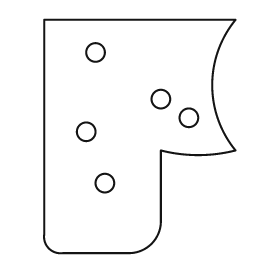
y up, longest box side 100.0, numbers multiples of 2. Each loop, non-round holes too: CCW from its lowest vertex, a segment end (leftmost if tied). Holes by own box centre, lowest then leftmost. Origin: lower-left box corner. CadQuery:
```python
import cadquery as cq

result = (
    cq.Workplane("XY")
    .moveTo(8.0, 0.0)
    .lineTo(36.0, 0.0)
    .threePointArc((46.0, 4.0), (50.0, 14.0))
    .lineTo(50.0, 44.0)
    .threePointArc((66.0, 42.0), (82.0, 44.0))
    .threePointArc((72.0, 72.0), (82.0, 100.0))
    .lineTo(0.0, 100.0)
    .lineTo(0.0, 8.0)
    .threePointArc((2.0, 2.0), (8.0, 0.0))
    .close()
    .moveTo(26.0, 30.0)
    .circle(4.0)
    .moveTo(18.0, 52.0)
    .circle(4.0)
    .moveTo(62.0, 58.0)
    .circle(4.0)
    .moveTo(50.0, 66.0)
    .circle(4.0)
    .moveTo(22.0, 86.0)
    .circle(4.0)
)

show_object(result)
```